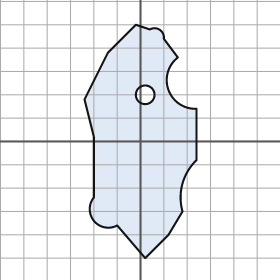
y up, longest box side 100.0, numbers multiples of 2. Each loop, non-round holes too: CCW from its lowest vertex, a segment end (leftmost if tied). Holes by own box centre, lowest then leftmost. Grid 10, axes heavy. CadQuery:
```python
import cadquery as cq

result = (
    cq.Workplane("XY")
    .moveTo(2.0, -50.0)
    .lineTo(12.0, -40.0)
    .lineTo(18.0, -30.0)
    .threePointArc((18.0, -18.0), (24.0, -8.0))
    .lineTo(24.0, 14.0)
    .threePointArc((12.0, 22.0), (16.0, 36.0))
    .lineTo(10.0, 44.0)
    .threePointArc((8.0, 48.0), (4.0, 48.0))
    .lineTo(-2.0, 50.0)
    .lineTo(-14.0, 38.0)
    .lineTo(-24.0, 18.0)
    .lineTo(-20.0, 2.0)
    .lineTo(-20.0, -24.0)
    .threePointArc((-20.0, -34.0), (-10.0, -36.0))
    .close()
    .moveTo(2.0, 20.0)
    .circle(4.0)
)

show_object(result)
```